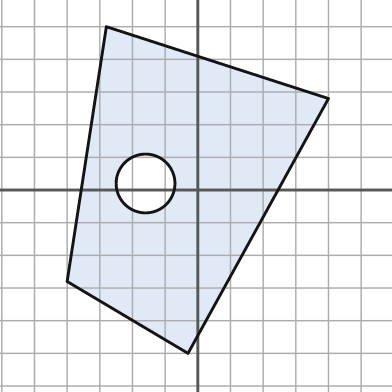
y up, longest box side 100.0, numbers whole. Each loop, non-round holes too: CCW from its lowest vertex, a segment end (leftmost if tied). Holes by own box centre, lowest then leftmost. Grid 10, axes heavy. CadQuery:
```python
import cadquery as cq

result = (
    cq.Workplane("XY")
    .moveTo(-3.0, -50.0)
    .lineTo(40.0, 28.0)
    .lineTo(-28.0, 50.0)
    .lineTo(-40.0, -28.0)
    .close()
    .moveTo(-16.0, 2.0)
    .circle(9.0)
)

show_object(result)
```